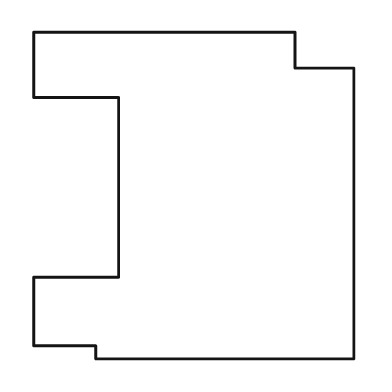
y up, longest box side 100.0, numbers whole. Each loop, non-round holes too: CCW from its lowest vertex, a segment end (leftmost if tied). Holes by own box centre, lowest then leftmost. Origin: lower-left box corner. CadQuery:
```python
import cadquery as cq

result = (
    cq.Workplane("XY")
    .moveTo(19.0, 0.0)
    .lineTo(98.0, 0.0)
    .lineTo(98.0, 89.0)
    .lineTo(80.0, 89.0)
    .lineTo(80.0, 100.0)
    .lineTo(0.0, 100.0)
    .lineTo(0.0, 80.0)
    .lineTo(26.0, 80.0)
    .lineTo(26.0, 25.0)
    .lineTo(0.0, 25.0)
    .lineTo(0.0, 4.0)
    .lineTo(19.0, 4.0)
    .close()
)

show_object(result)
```